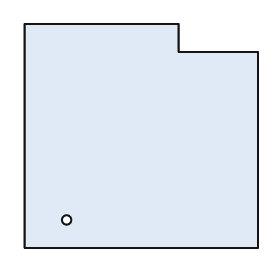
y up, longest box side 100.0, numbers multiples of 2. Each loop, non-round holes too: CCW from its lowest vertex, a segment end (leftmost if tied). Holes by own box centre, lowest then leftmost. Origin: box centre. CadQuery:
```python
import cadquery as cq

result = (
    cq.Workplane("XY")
    .moveTo(-50.0, -48.0)
    .lineTo(50.0, -48.0)
    .lineTo(50.0, 36.0)
    .lineTo(16.0, 36.0)
    .lineTo(16.0, 48.0)
    .lineTo(-50.0, 48.0)
    .close()
    .moveTo(-32.0, -36.0)
    .circle(2.0)
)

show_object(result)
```